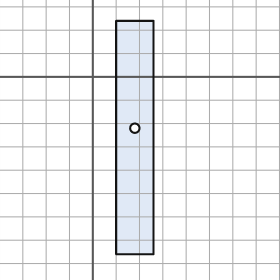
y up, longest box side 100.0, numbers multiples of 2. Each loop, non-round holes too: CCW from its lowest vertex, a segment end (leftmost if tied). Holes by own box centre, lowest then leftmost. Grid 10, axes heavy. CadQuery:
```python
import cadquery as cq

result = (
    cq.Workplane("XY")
    .moveTo(10.0, -76.0)
    .lineTo(26.0, -76.0)
    .lineTo(26.0, 24.0)
    .lineTo(10.0, 24.0)
    .close()
    .moveTo(18.0, -22.0)
    .circle(2.0)
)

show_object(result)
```